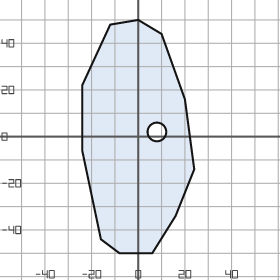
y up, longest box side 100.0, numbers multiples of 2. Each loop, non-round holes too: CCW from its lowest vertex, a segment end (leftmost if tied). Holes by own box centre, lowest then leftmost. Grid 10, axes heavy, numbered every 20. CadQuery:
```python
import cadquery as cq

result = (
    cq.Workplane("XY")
    .moveTo(-8.0, -50.0)
    .lineTo(6.0, -50.0)
    .lineTo(16.0, -34.0)
    .lineTo(24.0, -14.0)
    .lineTo(20.0, 16.0)
    .lineTo(10.0, 44.0)
    .lineTo(0.0, 50.0)
    .lineTo(-12.0, 48.0)
    .lineTo(-24.0, 22.0)
    .lineTo(-24.0, -6.0)
    .lineTo(-16.0, -44.0)
    .close()
    .moveTo(8.0, 2.0)
    .circle(4.0)
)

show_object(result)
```